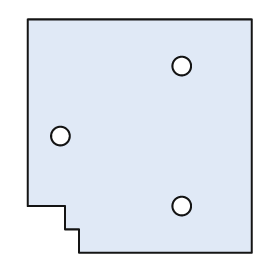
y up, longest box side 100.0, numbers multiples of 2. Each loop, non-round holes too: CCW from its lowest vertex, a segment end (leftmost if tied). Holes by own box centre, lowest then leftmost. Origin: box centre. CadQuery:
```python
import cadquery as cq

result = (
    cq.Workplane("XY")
    .moveTo(-26.0, -50.0)
    .lineTo(48.0, -50.0)
    .lineTo(48.0, 50.0)
    .lineTo(-48.0, 50.0)
    .lineTo(-48.0, -30.0)
    .lineTo(-32.0, -30.0)
    .lineTo(-32.0, -40.0)
    .lineTo(-26.0, -40.0)
    .close()
    .moveTo(18.0, -30.0)
    .circle(4.0)
    .moveTo(-34.0, 0.0)
    .circle(4.0)
    .moveTo(18.0, 30.0)
    .circle(4.0)
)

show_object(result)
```